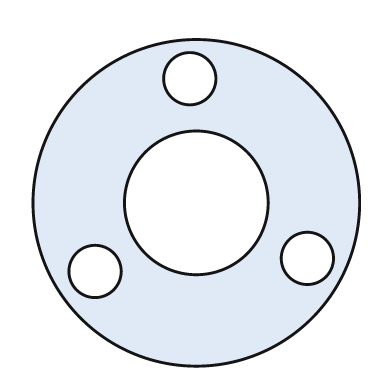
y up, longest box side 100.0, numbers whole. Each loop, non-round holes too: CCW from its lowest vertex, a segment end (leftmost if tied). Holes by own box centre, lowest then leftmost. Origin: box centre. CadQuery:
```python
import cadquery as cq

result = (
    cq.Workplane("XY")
    .moveTo(0.0, 0.0)
    .circle(50.0)
    .moveTo(-31.0, -21.0)
    .circle(8.0)
    .moveTo(34.0, -17.0)
    .circle(8.0)
    .moveTo(0.0, 0.0)
    .circle(22.0)
    .moveTo(-2.0, 38.0)
    .circle(8.0)
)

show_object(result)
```